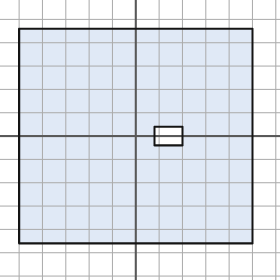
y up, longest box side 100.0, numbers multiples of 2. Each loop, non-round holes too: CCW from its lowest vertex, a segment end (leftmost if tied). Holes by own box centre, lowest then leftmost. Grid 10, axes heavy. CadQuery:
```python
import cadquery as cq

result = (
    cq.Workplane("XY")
    .moveTo(-50.0, -46.0)
    .lineTo(50.0, -46.0)
    .lineTo(50.0, 46.0)
    .lineTo(-50.0, 46.0)
    .close()
    .moveTo(8.0, -4.0)
    .lineTo(20.0, -4.0)
    .lineTo(20.0, 4.0)
    .lineTo(8.0, 4.0)
    .close()
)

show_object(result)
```